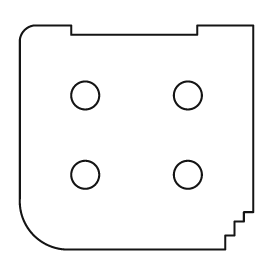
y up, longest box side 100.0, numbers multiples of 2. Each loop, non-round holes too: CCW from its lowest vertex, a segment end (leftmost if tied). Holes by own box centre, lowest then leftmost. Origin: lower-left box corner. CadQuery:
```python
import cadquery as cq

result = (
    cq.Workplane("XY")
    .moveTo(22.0, 0.0)
    .lineTo(88.0, 0.0)
    .lineTo(88.0, 6.0)
    .lineTo(92.0, 6.0)
    .lineTo(92.0, 12.0)
    .lineTo(96.0, 12.0)
    .lineTo(96.0, 16.0)
    .lineTo(100.0, 16.0)
    .lineTo(100.0, 96.0)
    .lineTo(76.0, 96.0)
    .lineTo(76.0, 92.0)
    .lineTo(22.0, 92.0)
    .lineTo(22.0, 96.0)
    .lineTo(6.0, 96.0)
    .threePointArc((2.0, 94.0), (0.0, 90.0))
    .lineTo(0.0, 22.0)
    .threePointArc((6.0, 6.0), (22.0, 0.0))
    .close()
    .moveTo(28.0, 32.0)
    .circle(6.0)
    .moveTo(72.0, 32.0)
    .circle(6.0)
    .moveTo(28.0, 66.0)
    .circle(6.0)
    .moveTo(72.0, 66.0)
    .circle(6.0)
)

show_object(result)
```